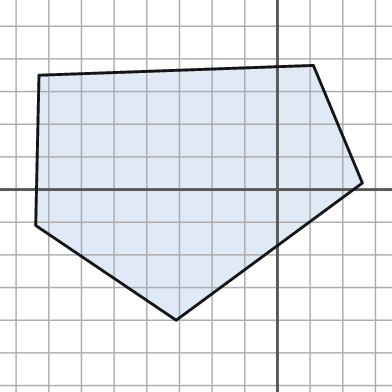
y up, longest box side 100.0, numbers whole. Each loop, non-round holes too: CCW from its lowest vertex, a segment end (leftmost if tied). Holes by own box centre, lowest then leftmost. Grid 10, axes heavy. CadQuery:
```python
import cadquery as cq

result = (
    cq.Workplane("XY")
    .moveTo(-31.0, -40.0)
    .lineTo(26.0, 2.0)
    .lineTo(11.0, 38.0)
    .lineTo(-73.0, 35.0)
    .lineTo(-74.0, -11.0)
    .close()
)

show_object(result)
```